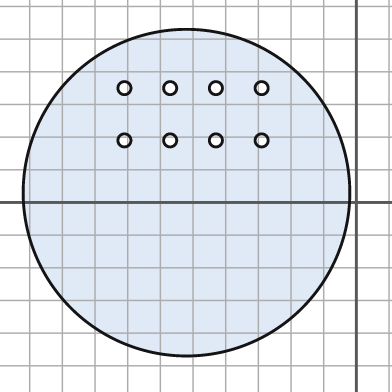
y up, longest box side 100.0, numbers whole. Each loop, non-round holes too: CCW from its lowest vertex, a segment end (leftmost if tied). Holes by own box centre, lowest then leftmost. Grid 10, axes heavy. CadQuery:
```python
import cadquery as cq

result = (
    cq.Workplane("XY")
    .moveTo(-52.0, 3.0)
    .circle(50.0)
    .moveTo(-71.0, 19.0)
    .circle(2.0)
    .moveTo(-57.0, 19.0)
    .circle(2.0)
    .moveTo(-43.0, 19.0)
    .circle(2.0)
    .moveTo(-29.0, 19.0)
    .circle(2.0)
    .moveTo(-71.0, 35.0)
    .circle(2.0)
    .moveTo(-57.0, 35.0)
    .circle(2.0)
    .moveTo(-43.0, 35.0)
    .circle(2.0)
    .moveTo(-29.0, 35.0)
    .circle(2.0)
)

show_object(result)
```